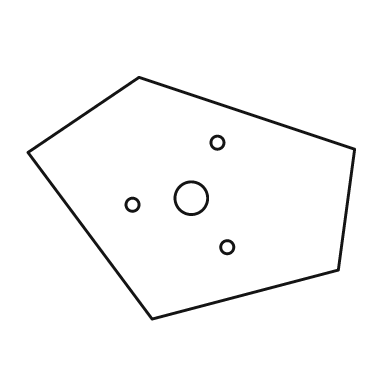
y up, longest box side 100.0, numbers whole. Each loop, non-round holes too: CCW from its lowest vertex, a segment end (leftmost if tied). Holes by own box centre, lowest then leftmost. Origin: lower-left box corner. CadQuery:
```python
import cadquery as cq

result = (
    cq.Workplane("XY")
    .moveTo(38.0, 0.0)
    .lineTo(95.0, 15.0)
    .lineTo(100.0, 52.0)
    .lineTo(34.0, 74.0)
    .lineTo(0.0, 51.0)
    .close()
    .moveTo(61.0, 22.0)
    .circle(2.0)
    .moveTo(32.0, 35.0)
    .circle(2.0)
    .moveTo(50.0, 37.0)
    .circle(5.0)
    .moveTo(58.0, 54.0)
    .circle(2.0)
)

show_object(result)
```